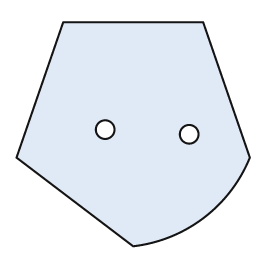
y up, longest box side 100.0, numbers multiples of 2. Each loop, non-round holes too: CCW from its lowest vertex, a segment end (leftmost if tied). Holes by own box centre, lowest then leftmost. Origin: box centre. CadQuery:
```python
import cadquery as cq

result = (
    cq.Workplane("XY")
    .moveTo(0.0, -48.0)
    .threePointArc((30.0, -36.0), (50.0, -10.0))
    .lineTo(30.0, 48.0)
    .lineTo(-30.0, 48.0)
    .lineTo(-50.0, -10.0)
    .close()
    .moveTo(24.0, 0.0)
    .circle(4.0)
    .moveTo(-12.0, 2.0)
    .circle(4.0)
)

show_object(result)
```